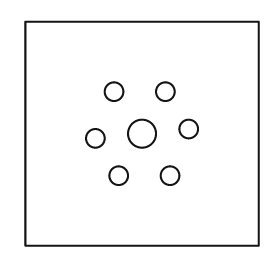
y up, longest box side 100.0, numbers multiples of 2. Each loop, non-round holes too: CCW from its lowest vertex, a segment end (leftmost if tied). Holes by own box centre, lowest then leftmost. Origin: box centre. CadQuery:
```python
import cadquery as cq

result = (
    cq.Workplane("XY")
    .moveTo(-50.0, -48.0)
    .lineTo(50.0, -48.0)
    .lineTo(50.0, 48.0)
    .lineTo(-50.0, 48.0)
    .close()
    .moveTo(-10.0, -18.0)
    .circle(4.0)
    .moveTo(12.0, -18.0)
    .circle(4.0)
    .moveTo(-20.0, -2.0)
    .circle(4.0)
    .moveTo(0.0, 0.0)
    .circle(6.0)
    .moveTo(20.0, 2.0)
    .circle(4.0)
    .moveTo(-12.0, 18.0)
    .circle(4.0)
    .moveTo(10.0, 18.0)
    .circle(4.0)
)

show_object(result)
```